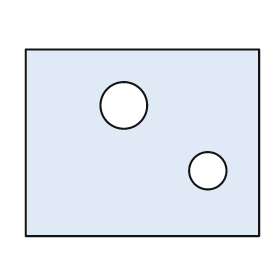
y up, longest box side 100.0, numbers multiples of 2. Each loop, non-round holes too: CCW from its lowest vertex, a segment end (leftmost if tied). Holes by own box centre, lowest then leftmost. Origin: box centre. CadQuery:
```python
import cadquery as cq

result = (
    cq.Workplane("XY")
    .moveTo(-50.0, -40.0)
    .lineTo(50.0, -40.0)
    .lineTo(50.0, 40.0)
    .lineTo(-50.0, 40.0)
    .close()
    .moveTo(28.0, -12.0)
    .circle(8.0)
    .moveTo(-8.0, 16.0)
    .circle(10.0)
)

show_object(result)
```